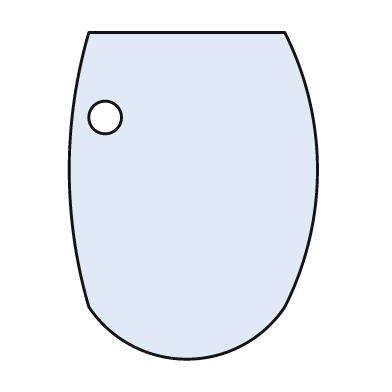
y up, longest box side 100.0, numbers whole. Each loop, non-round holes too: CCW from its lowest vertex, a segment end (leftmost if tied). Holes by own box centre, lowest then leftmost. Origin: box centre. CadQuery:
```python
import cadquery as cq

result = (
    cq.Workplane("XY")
    .moveTo(-32.0, -34.0)
    .threePointArc((-2.0, -50.0), (28.0, -34.0))
    .threePointArc((38.0, 8.0), (28.0, 50.0))
    .lineTo(-32.0, 50.0)
    .threePointArc((-38.0, 8.0), (-32.0, -34.0))
    .close()
    .moveTo(-27.0, 24.0)
    .circle(5.0)
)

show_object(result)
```